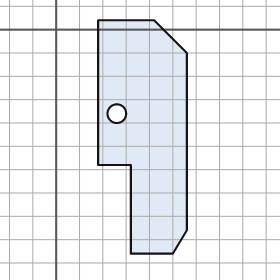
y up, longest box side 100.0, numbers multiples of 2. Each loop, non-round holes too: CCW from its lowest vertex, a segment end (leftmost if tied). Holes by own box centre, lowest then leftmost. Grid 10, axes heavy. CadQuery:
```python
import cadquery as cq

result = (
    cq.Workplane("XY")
    .moveTo(32.0, -96.0)
    .lineTo(50.0, -96.0)
    .lineTo(56.0, -86.0)
    .lineTo(56.0, -10.0)
    .lineTo(42.0, 4.0)
    .lineTo(18.0, 4.0)
    .lineTo(18.0, -58.0)
    .lineTo(32.0, -58.0)
    .close()
    .moveTo(26.0, -36.0)
    .circle(4.0)
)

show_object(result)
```